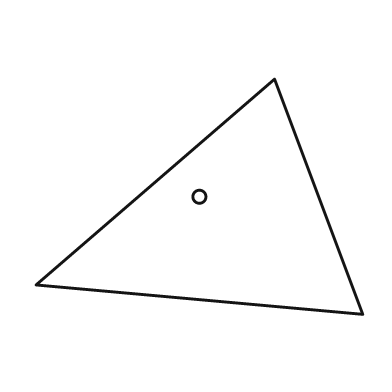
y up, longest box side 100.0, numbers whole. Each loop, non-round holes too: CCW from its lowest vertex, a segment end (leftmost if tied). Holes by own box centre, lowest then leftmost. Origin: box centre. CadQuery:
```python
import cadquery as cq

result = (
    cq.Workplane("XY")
    .moveTo(50.0, -36.0)
    .lineTo(23.0, 36.0)
    .lineTo(-50.0, -27.0)
    .close()
    .moveTo(0.0, 0.0)
    .circle(2.0)
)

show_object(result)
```